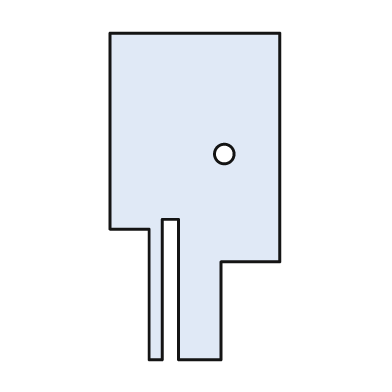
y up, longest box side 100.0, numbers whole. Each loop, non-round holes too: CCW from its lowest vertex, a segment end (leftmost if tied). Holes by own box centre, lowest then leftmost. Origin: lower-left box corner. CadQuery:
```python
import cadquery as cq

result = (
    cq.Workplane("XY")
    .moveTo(12.0, 0.0)
    .lineTo(16.0, 0.0)
    .lineTo(16.0, 43.0)
    .lineTo(21.0, 43.0)
    .lineTo(21.0, 0.0)
    .lineTo(34.0, 0.0)
    .lineTo(34.0, 30.0)
    .lineTo(52.0, 30.0)
    .lineTo(52.0, 100.0)
    .lineTo(0.0, 100.0)
    .lineTo(0.0, 40.0)
    .lineTo(12.0, 40.0)
    .close()
    .moveTo(35.0, 63.0)
    .circle(3.0)
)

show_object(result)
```